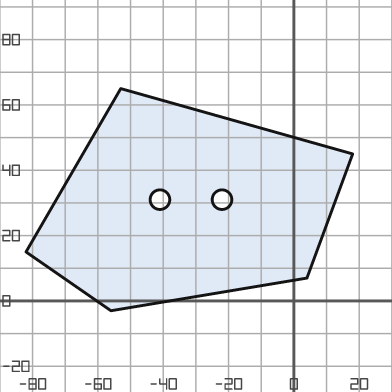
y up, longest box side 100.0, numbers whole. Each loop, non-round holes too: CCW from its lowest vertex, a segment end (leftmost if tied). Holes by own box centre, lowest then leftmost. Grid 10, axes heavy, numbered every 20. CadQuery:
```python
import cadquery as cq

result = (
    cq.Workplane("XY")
    .moveTo(-56.0, -3.0)
    .lineTo(4.0, 7.0)
    .lineTo(18.0, 45.0)
    .lineTo(-53.0, 65.0)
    .lineTo(-82.0, 15.0)
    .close()
    .moveTo(-41.0, 31.0)
    .circle(3.0)
    .moveTo(-22.0, 31.0)
    .circle(3.0)
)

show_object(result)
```